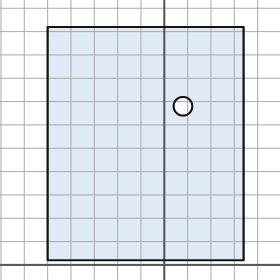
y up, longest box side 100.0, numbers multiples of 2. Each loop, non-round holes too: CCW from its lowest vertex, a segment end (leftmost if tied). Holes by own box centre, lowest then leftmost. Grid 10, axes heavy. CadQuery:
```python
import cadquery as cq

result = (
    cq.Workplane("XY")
    .moveTo(-50.0, 2.0)
    .lineTo(34.0, 2.0)
    .lineTo(34.0, 102.0)
    .lineTo(-50.0, 102.0)
    .close()
    .moveTo(8.0, 68.0)
    .circle(4.0)
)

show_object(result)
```